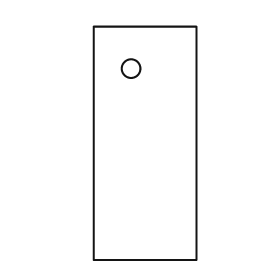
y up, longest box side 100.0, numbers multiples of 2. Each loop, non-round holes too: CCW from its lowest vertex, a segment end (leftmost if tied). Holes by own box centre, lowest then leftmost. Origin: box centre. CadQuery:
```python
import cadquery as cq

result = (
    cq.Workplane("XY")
    .moveTo(-22.0, -50.0)
    .lineTo(22.0, -50.0)
    .lineTo(22.0, 50.0)
    .lineTo(-22.0, 50.0)
    .close()
    .moveTo(-6.0, 32.0)
    .circle(4.0)
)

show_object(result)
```